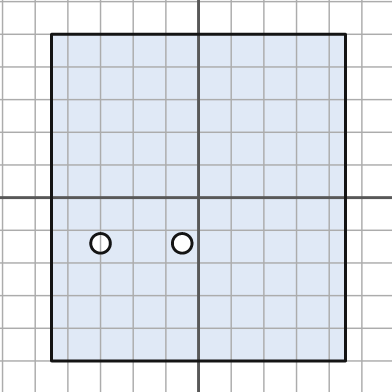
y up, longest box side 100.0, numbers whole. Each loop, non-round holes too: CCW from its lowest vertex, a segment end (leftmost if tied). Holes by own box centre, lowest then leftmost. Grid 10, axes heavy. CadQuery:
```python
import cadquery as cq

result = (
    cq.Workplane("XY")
    .moveTo(-45.0, -50.0)
    .lineTo(45.0, -50.0)
    .lineTo(45.0, 50.0)
    .lineTo(-45.0, 50.0)
    .close()
    .moveTo(-30.0, -14.0)
    .circle(3.0)
    .moveTo(-5.0, -14.0)
    .circle(3.0)
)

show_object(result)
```